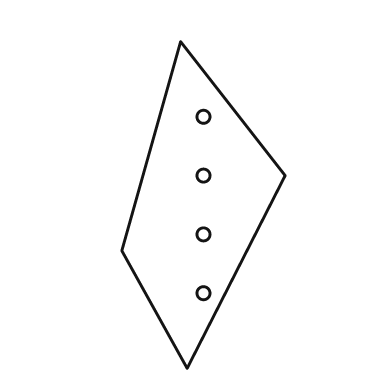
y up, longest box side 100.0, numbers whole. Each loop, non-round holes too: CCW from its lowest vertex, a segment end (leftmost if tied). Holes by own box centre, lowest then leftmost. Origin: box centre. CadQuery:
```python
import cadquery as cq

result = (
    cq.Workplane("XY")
    .moveTo(-5.0, -50.0)
    .lineTo(25.0, 9.0)
    .lineTo(-7.0, 50.0)
    .lineTo(-25.0, -14.0)
    .close()
    .moveTo(0.0, -27.0)
    .circle(2.0)
    .moveTo(0.0, -9.0)
    .circle(2.0)
    .moveTo(0.0, 9.0)
    .circle(2.0)
    .moveTo(0.0, 27.0)
    .circle(2.0)
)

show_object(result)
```